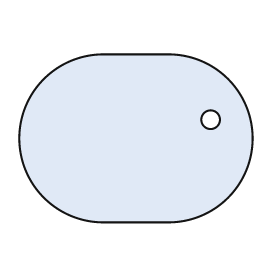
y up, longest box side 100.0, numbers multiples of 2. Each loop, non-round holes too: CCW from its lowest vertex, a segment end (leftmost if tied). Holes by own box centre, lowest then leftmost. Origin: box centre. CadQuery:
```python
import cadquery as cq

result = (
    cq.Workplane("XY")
    .moveTo(-14.0, -36.0)
    .lineTo(14.0, -36.0)
    .threePointArc((50.0, 0.0), (14.0, 36.0))
    .lineTo(-14.0, 36.0)
    .threePointArc((-50.0, 0.0), (-14.0, -36.0))
    .close()
    .moveTo(32.0, 8.0)
    .circle(4.0)
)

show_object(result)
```